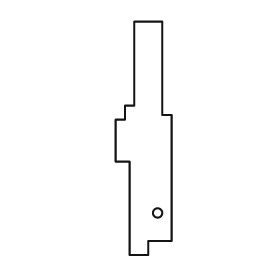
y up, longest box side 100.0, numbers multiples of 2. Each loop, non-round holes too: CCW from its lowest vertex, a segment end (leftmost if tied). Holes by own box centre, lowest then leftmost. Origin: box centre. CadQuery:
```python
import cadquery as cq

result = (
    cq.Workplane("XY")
    .moveTo(-6.0, -50.0)
    .lineTo(2.0, -50.0)
    .lineTo(2.0, -44.0)
    .lineTo(12.0, -44.0)
    .lineTo(12.0, 10.0)
    .lineTo(8.0, 10.0)
    .lineTo(8.0, 50.0)
    .lineTo(-4.0, 50.0)
    .lineTo(-4.0, 14.0)
    .lineTo(-8.0, 14.0)
    .lineTo(-8.0, 8.0)
    .lineTo(-12.0, 8.0)
    .lineTo(-12.0, -10.0)
    .lineTo(-6.0, -10.0)
    .close()
    .moveTo(6.0, -32.0)
    .circle(2.0)
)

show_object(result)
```